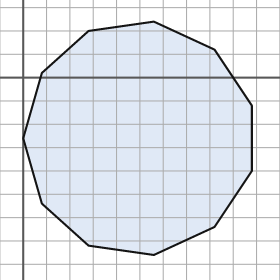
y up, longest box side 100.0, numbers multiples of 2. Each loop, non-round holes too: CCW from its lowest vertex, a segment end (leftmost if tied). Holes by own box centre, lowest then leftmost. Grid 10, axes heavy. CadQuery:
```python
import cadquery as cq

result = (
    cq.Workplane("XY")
    .moveTo(56.0, -76.0)
    .lineTo(82.0, -64.0)
    .lineTo(98.0, -40.0)
    .lineTo(98.0, -12.0)
    .lineTo(82.0, 12.0)
    .lineTo(56.0, 24.0)
    .lineTo(28.0, 20.0)
    .lineTo(8.0, 2.0)
    .lineTo(0.0, -26.0)
    .lineTo(8.0, -54.0)
    .lineTo(28.0, -72.0)
    .close()
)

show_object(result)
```